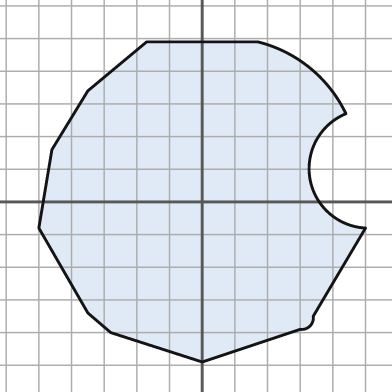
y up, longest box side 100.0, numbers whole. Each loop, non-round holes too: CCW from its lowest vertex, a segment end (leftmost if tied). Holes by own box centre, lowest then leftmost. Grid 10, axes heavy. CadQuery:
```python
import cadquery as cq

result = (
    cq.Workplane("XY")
    .moveTo(0.0, -49.0)
    .lineTo(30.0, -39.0)
    .threePointArc((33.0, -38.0), (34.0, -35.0))
    .lineTo(50.0, -8.0)
    .threePointArc((33.0, 7.0), (44.0, 27.0))
    .threePointArc((33.0, 41.0), (17.0, 49.0))
    .lineTo(-17.0, 49.0)
    .lineTo(-35.0, 34.0)
    .lineTo(-46.0, 16.0)
    .lineTo(-50.0, -8.0)
    .lineTo(-35.0, -34.0)
    .lineTo(-28.0, -40.0)
    .close()
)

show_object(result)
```